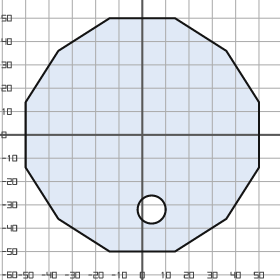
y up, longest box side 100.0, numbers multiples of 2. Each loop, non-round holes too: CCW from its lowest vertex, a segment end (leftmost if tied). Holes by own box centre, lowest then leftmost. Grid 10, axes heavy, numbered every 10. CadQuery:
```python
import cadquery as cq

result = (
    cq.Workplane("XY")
    .moveTo(-14.0, -50.0)
    .lineTo(14.0, -50.0)
    .lineTo(36.0, -36.0)
    .lineTo(50.0, -14.0)
    .lineTo(50.0, 14.0)
    .lineTo(36.0, 36.0)
    .lineTo(14.0, 50.0)
    .lineTo(-14.0, 50.0)
    .lineTo(-36.0, 36.0)
    .lineTo(-50.0, 14.0)
    .lineTo(-50.0, -14.0)
    .lineTo(-36.0, -36.0)
    .close()
    .moveTo(4.0, -32.0)
    .circle(6.0)
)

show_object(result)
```